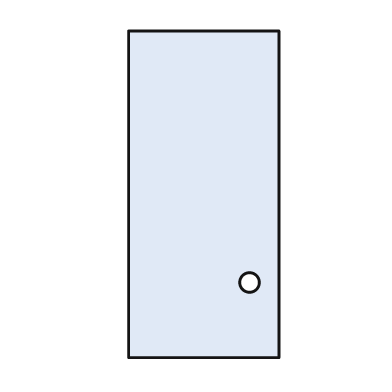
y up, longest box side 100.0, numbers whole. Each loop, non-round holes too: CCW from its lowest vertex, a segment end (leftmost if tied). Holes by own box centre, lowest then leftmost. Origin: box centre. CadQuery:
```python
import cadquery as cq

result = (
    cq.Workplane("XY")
    .moveTo(-23.0, -50.0)
    .lineTo(23.0, -50.0)
    .lineTo(23.0, 50.0)
    .lineTo(-23.0, 50.0)
    .close()
    .moveTo(14.0, -27.0)
    .circle(3.0)
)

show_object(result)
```